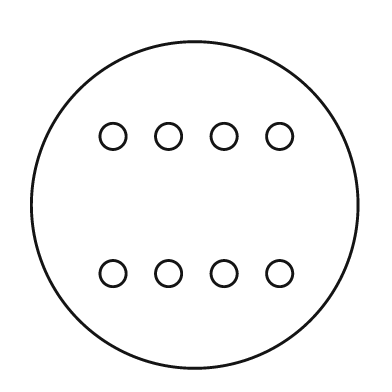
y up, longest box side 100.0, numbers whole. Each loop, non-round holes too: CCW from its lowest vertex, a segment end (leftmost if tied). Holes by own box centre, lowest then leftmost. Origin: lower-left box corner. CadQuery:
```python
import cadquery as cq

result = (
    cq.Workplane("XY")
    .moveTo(50.0, 50.0)
    .circle(50.0)
    .moveTo(25.0, 29.0)
    .circle(4.0)
    .moveTo(42.0, 29.0)
    .circle(4.0)
    .moveTo(59.0, 29.0)
    .circle(4.0)
    .moveTo(76.0, 29.0)
    .circle(4.0)
    .moveTo(25.0, 71.0)
    .circle(4.0)
    .moveTo(42.0, 71.0)
    .circle(4.0)
    .moveTo(59.0, 71.0)
    .circle(4.0)
    .moveTo(76.0, 71.0)
    .circle(4.0)
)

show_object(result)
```